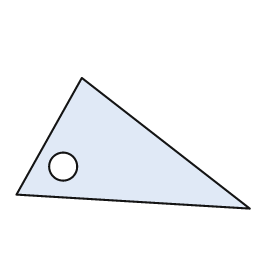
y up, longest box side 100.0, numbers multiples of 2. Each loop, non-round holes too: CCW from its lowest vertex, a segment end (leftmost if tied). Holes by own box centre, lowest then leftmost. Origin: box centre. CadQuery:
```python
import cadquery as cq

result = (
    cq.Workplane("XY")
    .moveTo(50.0, -28.0)
    .lineTo(-22.0, 28.0)
    .lineTo(-50.0, -22.0)
    .close()
    .moveTo(-30.0, -10.0)
    .circle(6.0)
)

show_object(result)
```